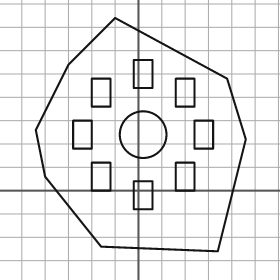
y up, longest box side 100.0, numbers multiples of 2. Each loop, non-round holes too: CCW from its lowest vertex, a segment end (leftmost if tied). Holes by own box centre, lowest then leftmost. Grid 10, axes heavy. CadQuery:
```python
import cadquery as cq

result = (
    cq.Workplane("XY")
    .moveTo(34.0, -26.0)
    .lineTo(46.0, 22.0)
    .lineTo(38.0, 48.0)
    .lineTo(-10.0, 74.0)
    .lineTo(-30.0, 54.0)
    .lineTo(-44.0, 26.0)
    .lineTo(-40.0, 6.0)
    .lineTo(-16.0, -24.0)
    .close()
    .moveTo(-2.0, -8.0)
    .lineTo(6.0, -8.0)
    .lineTo(6.0, 4.0)
    .lineTo(-2.0, 4.0)
    .close()
    .moveTo(-20.0, 0.0)
    .lineTo(-12.0, 0.0)
    .lineTo(-12.0, 12.0)
    .lineTo(-20.0, 12.0)
    .close()
    .moveTo(16.0, 0.0)
    .lineTo(24.0, 0.0)
    .lineTo(24.0, 12.0)
    .lineTo(16.0, 12.0)
    .close()
    .moveTo(-28.0, 18.0)
    .lineTo(-20.0, 18.0)
    .lineTo(-20.0, 30.0)
    .lineTo(-28.0, 30.0)
    .close()
    .moveTo(2.0, 24.0)
    .circle(10.0)
    .moveTo(24.0, 18.0)
    .lineTo(32.0, 18.0)
    .lineTo(32.0, 30.0)
    .lineTo(24.0, 30.0)
    .close()
    .moveTo(-20.0, 36.0)
    .lineTo(-12.0, 36.0)
    .lineTo(-12.0, 48.0)
    .lineTo(-20.0, 48.0)
    .close()
    .moveTo(16.0, 36.0)
    .lineTo(24.0, 36.0)
    .lineTo(24.0, 48.0)
    .lineTo(16.0, 48.0)
    .close()
    .moveTo(-2.0, 44.0)
    .lineTo(6.0, 44.0)
    .lineTo(6.0, 56.0)
    .lineTo(-2.0, 56.0)
    .close()
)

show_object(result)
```